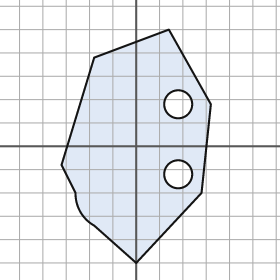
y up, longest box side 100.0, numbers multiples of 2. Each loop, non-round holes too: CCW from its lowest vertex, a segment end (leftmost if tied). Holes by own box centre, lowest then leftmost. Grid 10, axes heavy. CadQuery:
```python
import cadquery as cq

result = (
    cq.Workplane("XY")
    .moveTo(0.0, -50.0)
    .lineTo(28.0, -20.0)
    .lineTo(32.0, 18.0)
    .lineTo(14.0, 50.0)
    .lineTo(-18.0, 38.0)
    .lineTo(-32.0, -8.0)
    .lineTo(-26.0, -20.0)
    .threePointArc((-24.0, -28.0), (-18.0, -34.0))
    .close()
    .moveTo(18.0, -12.0)
    .circle(6.0)
    .moveTo(18.0, 18.0)
    .circle(6.0)
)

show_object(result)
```